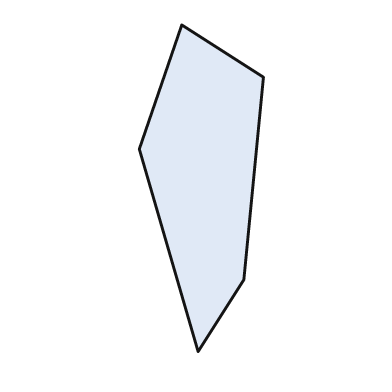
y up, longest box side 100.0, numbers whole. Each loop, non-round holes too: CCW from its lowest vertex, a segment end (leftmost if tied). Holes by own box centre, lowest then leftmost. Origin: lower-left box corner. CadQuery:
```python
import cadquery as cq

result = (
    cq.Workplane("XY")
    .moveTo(18.0, 0.0)
    .lineTo(32.0, 22.0)
    .lineTo(38.0, 84.0)
    .lineTo(13.0, 100.0)
    .lineTo(0.0, 62.0)
    .close()
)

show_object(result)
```